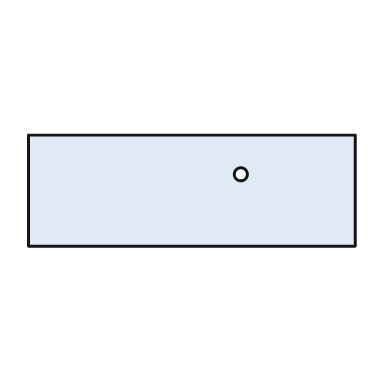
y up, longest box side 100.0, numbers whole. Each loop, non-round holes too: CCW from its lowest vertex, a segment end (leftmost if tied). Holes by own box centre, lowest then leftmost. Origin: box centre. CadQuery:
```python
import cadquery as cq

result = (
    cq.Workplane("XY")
    .moveTo(-50.0, -17.0)
    .lineTo(50.0, -17.0)
    .lineTo(50.0, 17.0)
    .lineTo(-50.0, 17.0)
    .close()
    .moveTo(15.0, 5.0)
    .circle(2.0)
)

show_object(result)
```